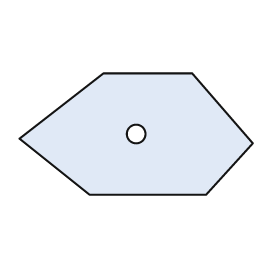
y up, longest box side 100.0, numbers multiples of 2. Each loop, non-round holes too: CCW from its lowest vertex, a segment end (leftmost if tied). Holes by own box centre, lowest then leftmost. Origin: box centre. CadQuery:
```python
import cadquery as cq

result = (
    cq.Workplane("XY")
    .moveTo(-20.0, -26.0)
    .lineTo(30.0, -26.0)
    .lineTo(50.0, -4.0)
    .lineTo(24.0, 26.0)
    .lineTo(-14.0, 26.0)
    .lineTo(-50.0, -2.0)
    .close()
    .moveTo(0.0, 0.0)
    .circle(4.0)
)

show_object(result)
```